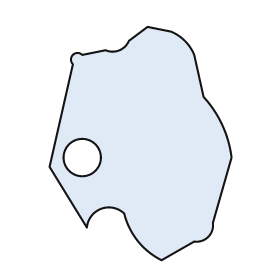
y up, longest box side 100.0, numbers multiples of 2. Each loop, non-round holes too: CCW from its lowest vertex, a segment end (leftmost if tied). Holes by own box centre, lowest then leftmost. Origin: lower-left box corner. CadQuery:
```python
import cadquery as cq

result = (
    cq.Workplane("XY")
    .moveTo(48.0, 0.0)
    .lineTo(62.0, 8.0)
    .threePointArc((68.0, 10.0), (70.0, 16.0))
    .lineTo(78.0, 44.0)
    .threePointArc((74.0, 58.0), (66.0, 70.0))
    .lineTo(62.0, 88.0)
    .threePointArc((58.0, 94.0), (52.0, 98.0))
    .lineTo(42.0, 100.0)
    .lineTo(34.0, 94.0)
    .threePointArc((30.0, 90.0), (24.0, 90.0))
    .lineTo(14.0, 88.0)
    .threePointArc((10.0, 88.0), (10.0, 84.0))
    .lineTo(0.0, 40.0)
    .lineTo(16.0, 14.0)
    .threePointArc((22.0, 22.0), (32.0, 20.0))
    .threePointArc((38.0, 8.0), (48.0, 0.0))
    .close()
    .moveTo(14.0, 44.0)
    .circle(8.0)
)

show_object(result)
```